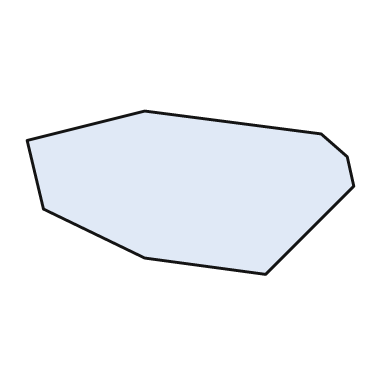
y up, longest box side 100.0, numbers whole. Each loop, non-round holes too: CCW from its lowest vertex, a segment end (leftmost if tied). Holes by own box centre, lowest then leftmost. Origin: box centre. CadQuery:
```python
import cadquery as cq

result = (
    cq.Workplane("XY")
    .moveTo(23.0, -25.0)
    .lineTo(50.0, 2.0)
    .lineTo(48.0, 11.0)
    .lineTo(40.0, 18.0)
    .lineTo(-14.0, 25.0)
    .lineTo(-50.0, 16.0)
    .lineTo(-45.0, -5.0)
    .lineTo(-14.0, -20.0)
    .close()
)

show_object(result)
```